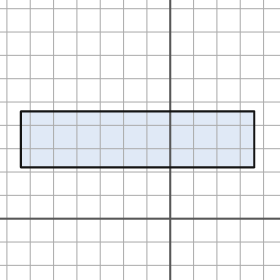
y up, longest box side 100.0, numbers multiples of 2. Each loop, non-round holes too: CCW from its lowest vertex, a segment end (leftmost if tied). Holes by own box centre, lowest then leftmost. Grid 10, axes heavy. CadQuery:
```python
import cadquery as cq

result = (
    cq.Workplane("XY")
    .moveTo(-64.0, 22.0)
    .lineTo(36.0, 22.0)
    .lineTo(36.0, 46.0)
    .lineTo(-64.0, 46.0)
    .close()
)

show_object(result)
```